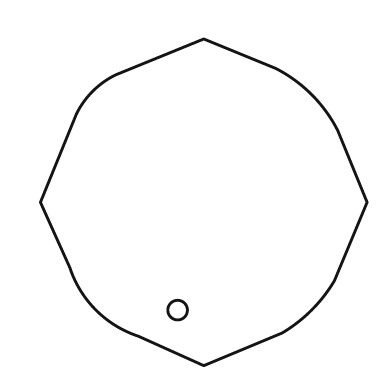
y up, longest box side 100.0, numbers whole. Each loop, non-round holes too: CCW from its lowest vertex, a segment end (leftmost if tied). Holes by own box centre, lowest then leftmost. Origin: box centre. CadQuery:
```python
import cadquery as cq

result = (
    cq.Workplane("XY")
    .moveTo(0.0, -50.0)
    .lineTo(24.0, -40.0)
    .threePointArc((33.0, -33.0), (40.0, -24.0))
    .lineTo(50.0, 0.0)
    .lineTo(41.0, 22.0)
    .threePointArc((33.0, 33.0), (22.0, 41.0))
    .lineTo(0.0, 50.0)
    .lineTo(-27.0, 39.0)
    .threePointArc((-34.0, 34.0), (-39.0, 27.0))
    .lineTo(-50.0, 0.0)
    .lineTo(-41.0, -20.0)
    .threePointArc((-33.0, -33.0), (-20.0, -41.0))
    .close()
    .moveTo(-8.0, -33.0)
    .circle(3.0)
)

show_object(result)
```